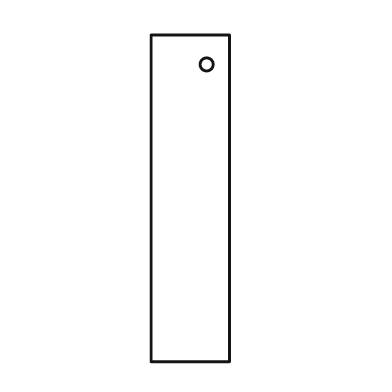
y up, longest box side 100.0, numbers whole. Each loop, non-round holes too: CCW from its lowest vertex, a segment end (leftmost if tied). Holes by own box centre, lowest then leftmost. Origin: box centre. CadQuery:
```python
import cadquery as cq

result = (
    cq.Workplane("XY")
    .moveTo(-12.0, -50.0)
    .lineTo(12.0, -50.0)
    .lineTo(12.0, 50.0)
    .lineTo(-12.0, 50.0)
    .close()
    .moveTo(5.0, 41.0)
    .circle(2.0)
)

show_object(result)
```